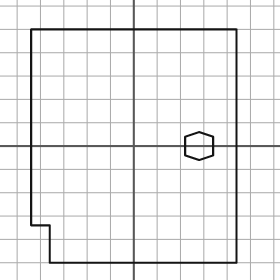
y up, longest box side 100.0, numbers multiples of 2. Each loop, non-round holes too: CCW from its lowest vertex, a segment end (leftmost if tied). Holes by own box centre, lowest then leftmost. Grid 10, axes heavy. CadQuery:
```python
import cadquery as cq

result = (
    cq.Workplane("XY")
    .moveTo(-36.0, -50.0)
    .lineTo(44.0, -50.0)
    .lineTo(44.0, 50.0)
    .lineTo(-44.0, 50.0)
    .lineTo(-44.0, -34.0)
    .lineTo(-36.0, -34.0)
    .close()
    .moveTo(28.0, -6.0)
    .lineTo(34.0, -4.0)
    .lineTo(34.0, 4.0)
    .lineTo(28.0, 6.0)
    .lineTo(22.0, 4.0)
    .lineTo(22.0, -4.0)
    .close()
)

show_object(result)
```